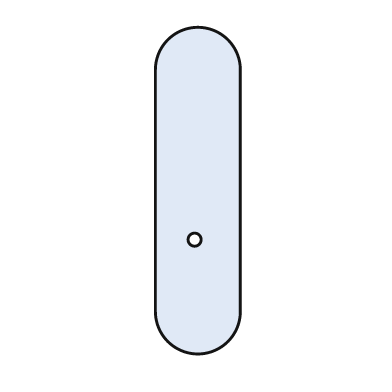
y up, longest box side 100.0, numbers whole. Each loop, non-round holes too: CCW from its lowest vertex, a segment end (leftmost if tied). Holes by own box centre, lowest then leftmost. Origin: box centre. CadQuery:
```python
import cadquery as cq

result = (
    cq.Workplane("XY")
    .moveTo(-13.0, -37.0)
    .threePointArc((0.0, -50.0), (13.0, -37.0))
    .lineTo(13.0, 37.0)
    .threePointArc((0.0, 50.0), (-13.0, 37.0))
    .close()
    .moveTo(-1.0, -15.0)
    .circle(2.0)
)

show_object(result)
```